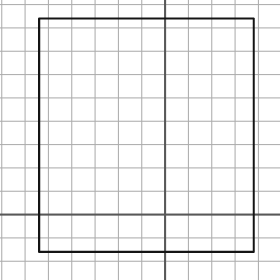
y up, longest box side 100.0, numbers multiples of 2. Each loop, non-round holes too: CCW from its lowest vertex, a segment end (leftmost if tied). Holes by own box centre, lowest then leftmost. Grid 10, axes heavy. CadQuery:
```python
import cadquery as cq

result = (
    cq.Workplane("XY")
    .moveTo(-54.0, -16.0)
    .lineTo(38.0, -16.0)
    .lineTo(38.0, 84.0)
    .lineTo(-54.0, 84.0)
    .close()
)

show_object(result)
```